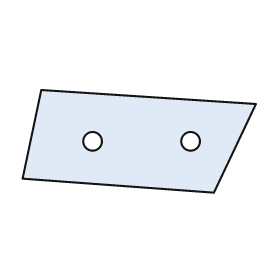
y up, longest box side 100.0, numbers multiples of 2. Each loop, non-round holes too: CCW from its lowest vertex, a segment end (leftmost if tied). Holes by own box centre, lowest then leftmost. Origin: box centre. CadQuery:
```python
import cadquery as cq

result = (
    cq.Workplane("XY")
    .moveTo(32.0, -22.0)
    .lineTo(50.0, 16.0)
    .lineTo(-42.0, 22.0)
    .lineTo(-50.0, -16.0)
    .close()
    .moveTo(-20.0, 0.0)
    .circle(4.0)
    .moveTo(22.0, 0.0)
    .circle(4.0)
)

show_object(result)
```